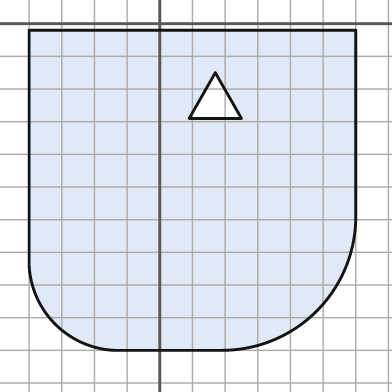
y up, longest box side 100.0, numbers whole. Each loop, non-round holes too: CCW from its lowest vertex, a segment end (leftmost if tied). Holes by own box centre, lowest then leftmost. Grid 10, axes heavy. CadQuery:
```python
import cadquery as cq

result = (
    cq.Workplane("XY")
    .moveTo(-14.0, -100.0)
    .lineTo(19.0, -100.0)
    .threePointArc((48.0, -88.0), (60.0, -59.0))
    .lineTo(60.0, -2.0)
    .lineTo(-40.0, -2.0)
    .lineTo(-40.0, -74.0)
    .threePointArc((-32.0, -92.0), (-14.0, -100.0))
    .close()
    .moveTo(9.0, -29.0)
    .lineTo(25.0, -29.0)
    .lineTo(17.0, -15.0)
    .close()
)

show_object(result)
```